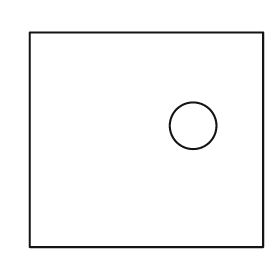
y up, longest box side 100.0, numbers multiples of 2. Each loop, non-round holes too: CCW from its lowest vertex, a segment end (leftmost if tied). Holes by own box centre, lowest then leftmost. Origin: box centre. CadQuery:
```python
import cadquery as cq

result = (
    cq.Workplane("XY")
    .moveTo(-50.0, -46.0)
    .lineTo(50.0, -46.0)
    .lineTo(50.0, 46.0)
    .lineTo(-50.0, 46.0)
    .close()
    .moveTo(20.0, 6.0)
    .circle(10.0)
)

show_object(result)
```